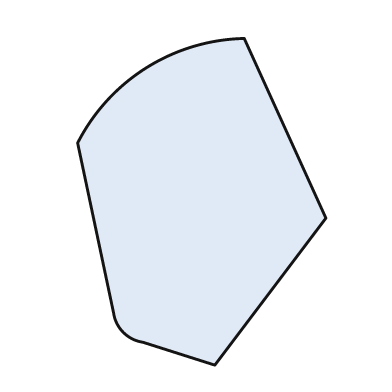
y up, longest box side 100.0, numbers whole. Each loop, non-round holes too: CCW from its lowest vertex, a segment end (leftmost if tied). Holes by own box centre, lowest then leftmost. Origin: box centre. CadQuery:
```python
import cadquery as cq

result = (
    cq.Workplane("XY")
    .moveTo(4.0, -50.0)
    .lineTo(38.0, -5.0)
    .lineTo(13.0, 50.0)
    .threePointArc((-17.0, 41.0), (-38.0, 18.0))
    .lineTo(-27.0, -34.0)
    .threePointArc((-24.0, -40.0), (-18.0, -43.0))
    .close()
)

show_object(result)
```